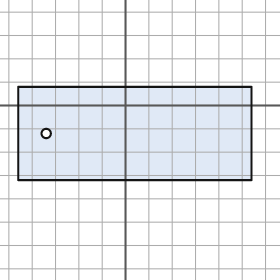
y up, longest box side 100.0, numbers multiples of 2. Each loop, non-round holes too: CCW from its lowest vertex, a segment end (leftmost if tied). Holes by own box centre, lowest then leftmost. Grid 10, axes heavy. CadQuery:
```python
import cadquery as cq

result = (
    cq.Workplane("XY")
    .moveTo(-46.0, -32.0)
    .lineTo(54.0, -32.0)
    .lineTo(54.0, 8.0)
    .lineTo(-46.0, 8.0)
    .close()
    .moveTo(-34.0, -12.0)
    .circle(2.0)
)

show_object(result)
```